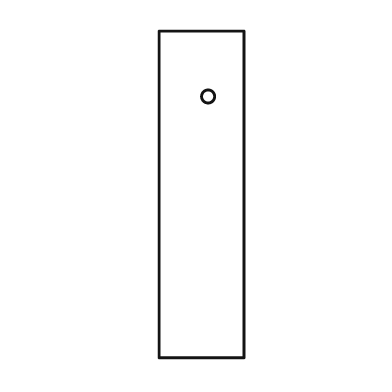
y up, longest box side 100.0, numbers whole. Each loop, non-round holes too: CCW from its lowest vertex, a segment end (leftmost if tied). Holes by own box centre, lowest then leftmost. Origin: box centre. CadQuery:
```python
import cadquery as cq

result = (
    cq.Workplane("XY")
    .moveTo(-13.0, -50.0)
    .lineTo(13.0, -50.0)
    .lineTo(13.0, 50.0)
    .lineTo(-13.0, 50.0)
    .close()
    .moveTo(2.0, 30.0)
    .circle(2.0)
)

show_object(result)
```